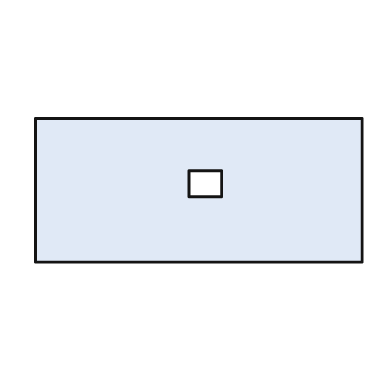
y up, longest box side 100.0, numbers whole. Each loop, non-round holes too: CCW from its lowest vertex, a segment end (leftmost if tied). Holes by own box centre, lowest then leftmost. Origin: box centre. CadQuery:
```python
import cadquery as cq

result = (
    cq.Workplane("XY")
    .moveTo(-50.0, -22.0)
    .lineTo(50.0, -22.0)
    .lineTo(50.0, 22.0)
    .lineTo(-50.0, 22.0)
    .close()
    .moveTo(-3.0, -2.0)
    .lineTo(7.0, -2.0)
    .lineTo(7.0, 6.0)
    .lineTo(-3.0, 6.0)
    .close()
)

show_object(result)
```